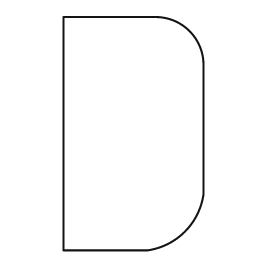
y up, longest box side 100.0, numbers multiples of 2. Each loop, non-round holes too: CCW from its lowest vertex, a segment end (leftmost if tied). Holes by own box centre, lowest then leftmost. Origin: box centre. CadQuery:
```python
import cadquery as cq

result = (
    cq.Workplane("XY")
    .moveTo(-30.0, -50.0)
    .lineTo(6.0, -50.0)
    .threePointArc((22.0, -42.0), (30.0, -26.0))
    .lineTo(30.0, 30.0)
    .threePointArc((24.0, 44.0), (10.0, 50.0))
    .lineTo(-30.0, 50.0)
    .close()
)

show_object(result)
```